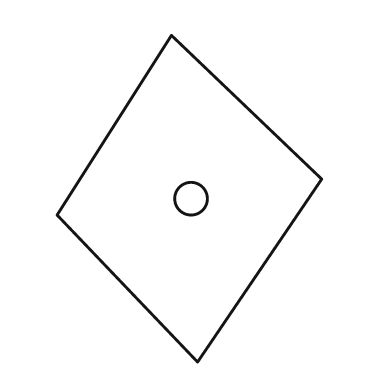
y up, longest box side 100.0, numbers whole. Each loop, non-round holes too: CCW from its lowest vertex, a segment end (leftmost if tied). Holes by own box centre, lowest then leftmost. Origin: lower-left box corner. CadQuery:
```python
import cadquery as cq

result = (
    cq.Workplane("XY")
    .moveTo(43.0, 0.0)
    .lineTo(81.0, 56.0)
    .lineTo(35.0, 100.0)
    .lineTo(0.0, 45.0)
    .close()
    .moveTo(41.0, 50.0)
    .circle(5.0)
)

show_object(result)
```